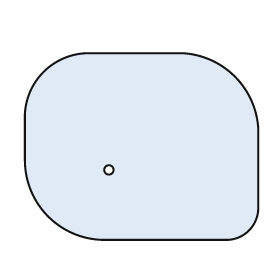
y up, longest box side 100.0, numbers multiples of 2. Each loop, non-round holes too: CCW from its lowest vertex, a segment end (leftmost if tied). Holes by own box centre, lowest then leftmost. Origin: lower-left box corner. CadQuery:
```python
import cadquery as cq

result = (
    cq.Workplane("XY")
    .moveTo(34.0, 0.0)
    .lineTo(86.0, 0.0)
    .threePointArc((96.0, 4.0), (100.0, 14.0))
    .lineTo(100.0, 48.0)
    .threePointArc((90.0, 70.0), (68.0, 80.0))
    .lineTo(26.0, 80.0)
    .threePointArc((8.0, 72.0), (0.0, 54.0))
    .lineTo(0.0, 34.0)
    .threePointArc((10.0, 10.0), (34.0, 0.0))
    .close()
    .moveTo(36.0, 30.0)
    .circle(2.0)
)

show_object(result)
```